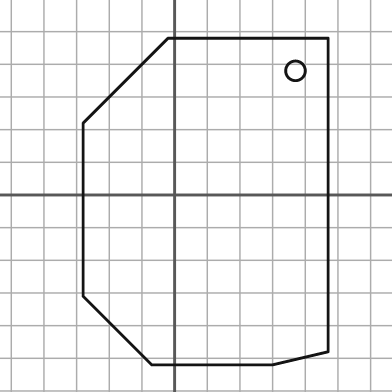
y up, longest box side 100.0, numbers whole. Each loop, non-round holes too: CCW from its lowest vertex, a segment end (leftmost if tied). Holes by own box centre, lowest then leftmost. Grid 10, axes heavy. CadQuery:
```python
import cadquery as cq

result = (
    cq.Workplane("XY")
    .moveTo(-7.0, -52.0)
    .lineTo(30.0, -52.0)
    .lineTo(47.0, -48.0)
    .lineTo(47.0, 48.0)
    .lineTo(-2.0, 48.0)
    .lineTo(-28.0, 22.0)
    .lineTo(-28.0, -31.0)
    .close()
    .moveTo(37.0, 38.0)
    .circle(3.0)
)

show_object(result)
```